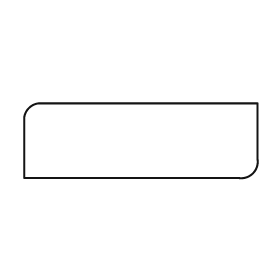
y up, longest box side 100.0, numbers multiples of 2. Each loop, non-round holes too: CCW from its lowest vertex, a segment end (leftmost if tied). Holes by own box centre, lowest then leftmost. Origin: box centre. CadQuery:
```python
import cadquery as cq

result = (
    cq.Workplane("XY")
    .moveTo(-50.0, -16.0)
    .lineTo(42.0, -16.0)
    .threePointArc((48.0, -14.0), (50.0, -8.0))
    .lineTo(50.0, 16.0)
    .lineTo(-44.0, 16.0)
    .threePointArc((-48.0, 14.0), (-50.0, 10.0))
    .close()
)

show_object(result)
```